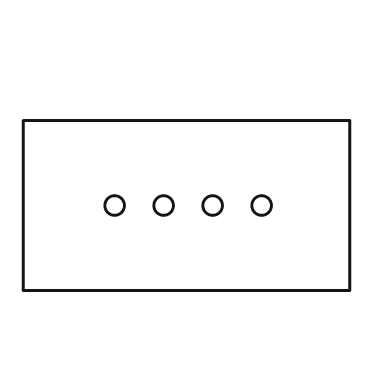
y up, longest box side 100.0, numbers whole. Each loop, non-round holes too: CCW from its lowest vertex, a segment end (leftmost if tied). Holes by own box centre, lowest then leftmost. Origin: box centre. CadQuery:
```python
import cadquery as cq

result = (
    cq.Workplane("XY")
    .moveTo(-50.0, -26.0)
    .lineTo(50.0, -26.0)
    .lineTo(50.0, 26.0)
    .lineTo(-50.0, 26.0)
    .close()
    .moveTo(-22.0, 0.0)
    .circle(3.0)
    .moveTo(-7.0, 0.0)
    .circle(3.0)
    .moveTo(8.0, 0.0)
    .circle(3.0)
    .moveTo(23.0, 0.0)
    .circle(3.0)
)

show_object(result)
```